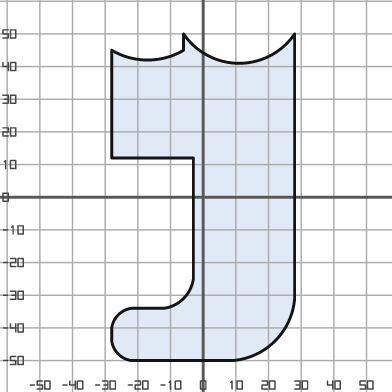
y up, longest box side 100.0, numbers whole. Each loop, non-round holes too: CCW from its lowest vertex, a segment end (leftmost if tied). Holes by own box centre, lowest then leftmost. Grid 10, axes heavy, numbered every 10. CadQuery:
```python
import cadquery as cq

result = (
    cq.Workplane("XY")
    .moveTo(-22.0, -50.0)
    .lineTo(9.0, -50.0)
    .threePointArc((22.0, -44.0), (28.0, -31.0))
    .lineTo(28.0, 50.0)
    .threePointArc((11.0, 41.0), (-6.0, 50.0))
    .lineTo(-6.0, 45.0)
    .threePointArc((-17.0, 42.0), (-28.0, 45.0))
    .lineTo(-28.0, 12.0)
    .lineTo(-3.0, 12.0)
    .lineTo(-3.0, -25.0)
    .threePointArc((-6.0, -31.0), (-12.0, -34.0))
    .lineTo(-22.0, -34.0)
    .threePointArc((-26.0, -36.0), (-28.0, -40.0))
    .lineTo(-28.0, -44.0)
    .threePointArc((-26.0, -48.0), (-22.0, -50.0))
    .close()
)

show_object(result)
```